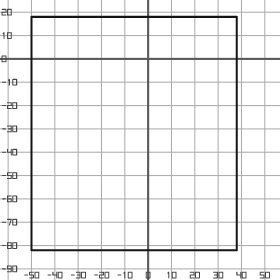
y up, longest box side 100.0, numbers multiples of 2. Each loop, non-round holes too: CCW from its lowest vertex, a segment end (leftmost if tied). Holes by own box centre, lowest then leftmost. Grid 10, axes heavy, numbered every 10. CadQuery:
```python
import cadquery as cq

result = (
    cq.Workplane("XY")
    .moveTo(-50.0, -82.0)
    .lineTo(38.0, -82.0)
    .lineTo(38.0, 18.0)
    .lineTo(-50.0, 18.0)
    .close()
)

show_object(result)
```